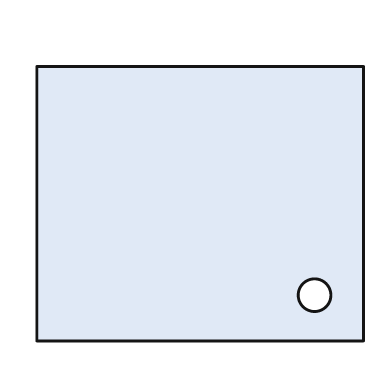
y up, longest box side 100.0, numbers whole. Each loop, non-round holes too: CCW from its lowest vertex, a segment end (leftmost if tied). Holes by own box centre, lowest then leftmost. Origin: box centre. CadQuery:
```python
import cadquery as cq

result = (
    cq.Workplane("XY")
    .moveTo(-50.0, -42.0)
    .lineTo(50.0, -42.0)
    .lineTo(50.0, 42.0)
    .lineTo(-50.0, 42.0)
    .close()
    .moveTo(35.0, -28.0)
    .circle(5.0)
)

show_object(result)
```